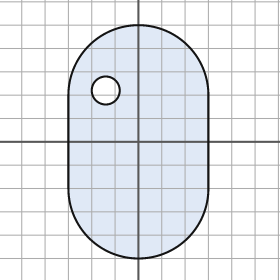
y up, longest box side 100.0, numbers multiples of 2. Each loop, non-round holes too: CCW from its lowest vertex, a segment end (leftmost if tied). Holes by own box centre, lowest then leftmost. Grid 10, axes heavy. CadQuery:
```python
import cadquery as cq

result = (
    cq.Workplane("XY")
    .moveTo(-30.0, -20.0)
    .threePointArc((0.0, -50.0), (30.0, -20.0))
    .lineTo(30.0, 20.0)
    .threePointArc((0.0, 50.0), (-30.0, 20.0))
    .close()
    .moveTo(-14.0, 22.0)
    .circle(6.0)
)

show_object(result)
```